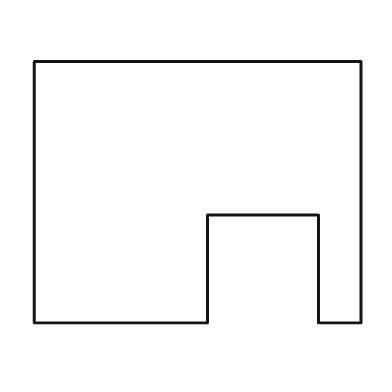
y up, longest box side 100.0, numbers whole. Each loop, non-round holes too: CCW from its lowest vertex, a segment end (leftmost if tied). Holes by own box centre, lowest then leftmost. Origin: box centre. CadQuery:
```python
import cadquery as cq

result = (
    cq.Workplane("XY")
    .moveTo(-50.0, -40.0)
    .lineTo(3.0, -40.0)
    .lineTo(3.0, -7.0)
    .lineTo(37.0, -7.0)
    .lineTo(37.0, -40.0)
    .lineTo(50.0, -40.0)
    .lineTo(50.0, 40.0)
    .lineTo(-50.0, 40.0)
    .close()
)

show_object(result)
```